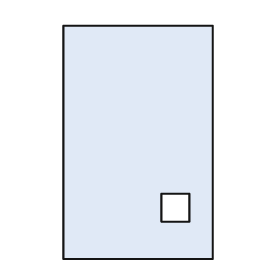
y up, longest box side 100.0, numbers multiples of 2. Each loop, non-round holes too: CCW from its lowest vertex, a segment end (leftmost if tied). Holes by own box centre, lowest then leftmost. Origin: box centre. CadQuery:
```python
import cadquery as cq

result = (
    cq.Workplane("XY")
    .moveTo(-32.0, -50.0)
    .lineTo(32.0, -50.0)
    .lineTo(32.0, 50.0)
    .lineTo(-32.0, 50.0)
    .close()
    .moveTo(10.0, -34.0)
    .lineTo(22.0, -34.0)
    .lineTo(22.0, -22.0)
    .lineTo(10.0, -22.0)
    .close()
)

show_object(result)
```